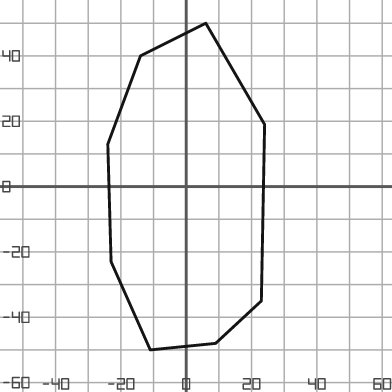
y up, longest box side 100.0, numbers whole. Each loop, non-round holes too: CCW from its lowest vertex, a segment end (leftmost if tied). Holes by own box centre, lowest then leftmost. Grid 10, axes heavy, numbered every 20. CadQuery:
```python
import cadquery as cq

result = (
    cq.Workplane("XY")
    .moveTo(-11.0, -50.0)
    .lineTo(9.0, -48.0)
    .lineTo(23.0, -35.0)
    .lineTo(24.0, 19.0)
    .lineTo(6.0, 50.0)
    .lineTo(-14.0, 40.0)
    .lineTo(-24.0, 13.0)
    .lineTo(-23.0, -23.0)
    .close()
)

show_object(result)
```